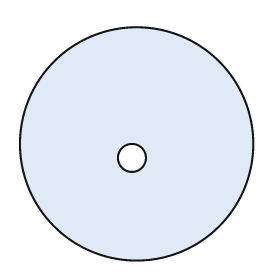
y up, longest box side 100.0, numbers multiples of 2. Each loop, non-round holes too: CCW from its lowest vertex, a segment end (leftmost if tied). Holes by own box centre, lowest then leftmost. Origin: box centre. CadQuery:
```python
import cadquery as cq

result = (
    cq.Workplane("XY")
    .moveTo(0.0, 0.0)
    .circle(50.0)
    .moveTo(-2.0, -6.0)
    .circle(6.0)
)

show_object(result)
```